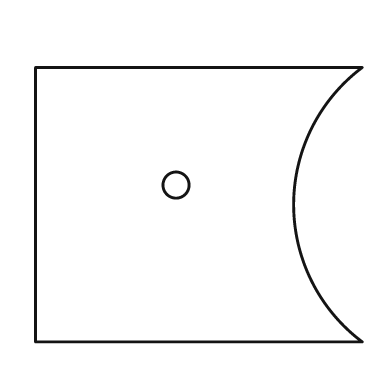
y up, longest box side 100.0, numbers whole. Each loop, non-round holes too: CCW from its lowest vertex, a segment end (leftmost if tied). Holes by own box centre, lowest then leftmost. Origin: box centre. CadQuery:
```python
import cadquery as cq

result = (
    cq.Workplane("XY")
    .moveTo(-50.0, -42.0)
    .lineTo(50.0, -42.0)
    .threePointArc((29.0, 0.0), (50.0, 42.0))
    .lineTo(-50.0, 42.0)
    .close()
    .moveTo(-7.0, 6.0)
    .circle(4.0)
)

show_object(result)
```